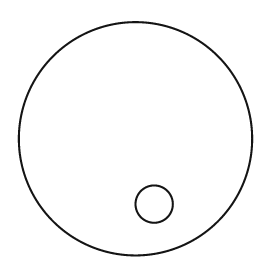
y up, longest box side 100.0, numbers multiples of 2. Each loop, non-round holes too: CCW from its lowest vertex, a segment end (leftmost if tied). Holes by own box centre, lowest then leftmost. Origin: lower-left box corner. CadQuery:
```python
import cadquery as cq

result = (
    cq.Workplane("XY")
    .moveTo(50.0, 50.0)
    .circle(50.0)
    .moveTo(58.0, 22.0)
    .circle(8.0)
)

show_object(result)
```